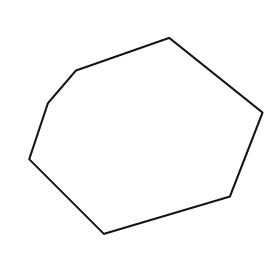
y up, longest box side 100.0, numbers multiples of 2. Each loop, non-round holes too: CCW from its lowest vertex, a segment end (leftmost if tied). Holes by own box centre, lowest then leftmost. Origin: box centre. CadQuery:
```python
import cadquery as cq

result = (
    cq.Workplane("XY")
    .moveTo(-18.0, -42.0)
    .lineTo(36.0, -26.0)
    .lineTo(50.0, 10.0)
    .lineTo(10.0, 42.0)
    .lineTo(-30.0, 28.0)
    .lineTo(-42.0, 14.0)
    .lineTo(-50.0, -10.0)
    .close()
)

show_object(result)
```